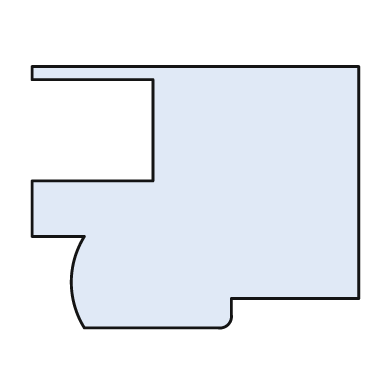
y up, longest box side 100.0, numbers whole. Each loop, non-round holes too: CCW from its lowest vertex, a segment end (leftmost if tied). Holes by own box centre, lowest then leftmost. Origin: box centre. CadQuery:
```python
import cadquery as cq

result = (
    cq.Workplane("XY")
    .moveTo(-34.0, -40.0)
    .lineTo(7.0, -40.0)
    .threePointArc((10.0, -39.0), (11.0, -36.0))
    .lineTo(11.0, -31.0)
    .lineTo(50.0, -31.0)
    .lineTo(50.0, 40.0)
    .lineTo(-50.0, 40.0)
    .lineTo(-50.0, 36.0)
    .lineTo(-13.0, 36.0)
    .lineTo(-13.0, 5.0)
    .lineTo(-50.0, 5.0)
    .lineTo(-50.0, -12.0)
    .lineTo(-34.0, -12.0)
    .threePointArc((-38.0, -26.0), (-34.0, -40.0))
    .close()
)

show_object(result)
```